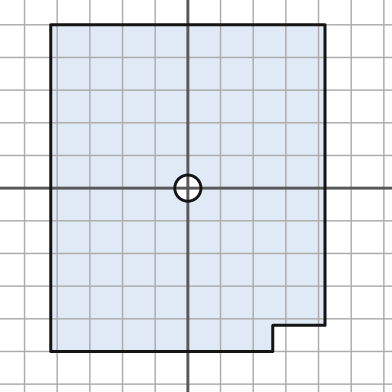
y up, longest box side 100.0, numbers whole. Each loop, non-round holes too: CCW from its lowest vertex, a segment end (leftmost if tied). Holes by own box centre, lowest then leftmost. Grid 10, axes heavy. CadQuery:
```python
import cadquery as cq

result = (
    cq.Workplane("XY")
    .moveTo(-42.0, -50.0)
    .lineTo(26.0, -50.0)
    .lineTo(26.0, -42.0)
    .lineTo(42.0, -42.0)
    .lineTo(42.0, 50.0)
    .lineTo(-42.0, 50.0)
    .close()
    .moveTo(0.0, 0.0)
    .circle(4.0)
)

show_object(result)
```